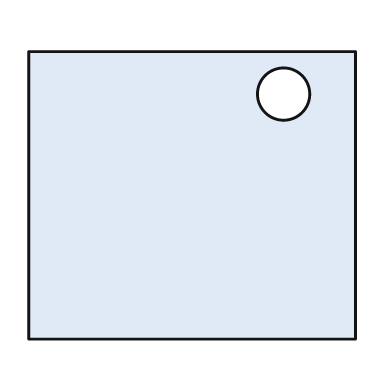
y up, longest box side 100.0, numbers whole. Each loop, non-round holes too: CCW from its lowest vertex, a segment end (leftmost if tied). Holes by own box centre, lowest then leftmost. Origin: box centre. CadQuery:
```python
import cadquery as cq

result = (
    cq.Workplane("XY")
    .moveTo(-50.0, -44.0)
    .lineTo(50.0, -44.0)
    .lineTo(50.0, 44.0)
    .lineTo(-50.0, 44.0)
    .close()
    .moveTo(28.0, 31.0)
    .circle(8.0)
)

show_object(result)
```